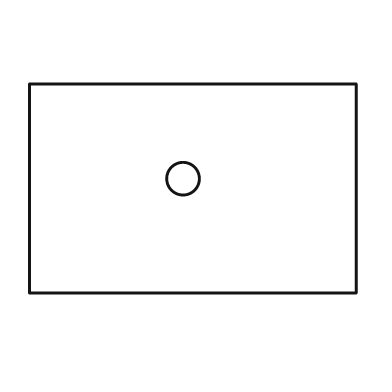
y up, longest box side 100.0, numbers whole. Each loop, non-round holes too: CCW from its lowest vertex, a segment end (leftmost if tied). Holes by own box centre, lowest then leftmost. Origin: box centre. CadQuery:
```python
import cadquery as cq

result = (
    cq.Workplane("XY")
    .moveTo(-50.0, -32.0)
    .lineTo(50.0, -32.0)
    .lineTo(50.0, 32.0)
    .lineTo(-50.0, 32.0)
    .close()
    .moveTo(-3.0, 3.0)
    .circle(5.0)
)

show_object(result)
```